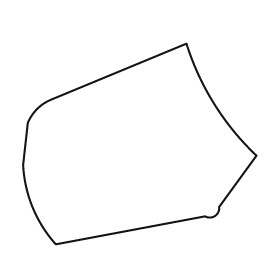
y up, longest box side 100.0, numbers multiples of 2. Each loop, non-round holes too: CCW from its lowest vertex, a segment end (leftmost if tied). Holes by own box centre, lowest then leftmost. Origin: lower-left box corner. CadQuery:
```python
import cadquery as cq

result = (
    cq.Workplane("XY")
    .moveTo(14.0, 0.0)
    .lineTo(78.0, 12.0)
    .threePointArc((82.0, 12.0), (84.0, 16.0))
    .lineTo(100.0, 38.0)
    .threePointArc((82.0, 60.0), (70.0, 86.0))
    .lineTo(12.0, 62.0)
    .threePointArc((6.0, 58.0), (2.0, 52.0))
    .lineTo(0.0, 34.0)
    .threePointArc((4.0, 16.0), (14.0, 0.0))
    .close()
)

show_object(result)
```